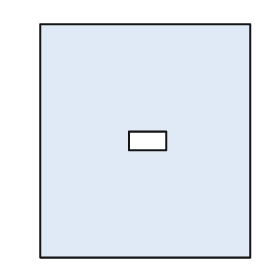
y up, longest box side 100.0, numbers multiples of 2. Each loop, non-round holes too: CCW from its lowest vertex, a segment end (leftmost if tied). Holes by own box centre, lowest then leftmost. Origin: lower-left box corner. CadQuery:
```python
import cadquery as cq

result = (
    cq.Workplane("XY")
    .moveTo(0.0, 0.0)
    .lineTo(90.0, 0.0)
    .lineTo(90.0, 100.0)
    .lineTo(0.0, 100.0)
    .close()
    .moveTo(38.0, 46.0)
    .lineTo(54.0, 46.0)
    .lineTo(54.0, 54.0)
    .lineTo(38.0, 54.0)
    .close()
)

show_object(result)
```